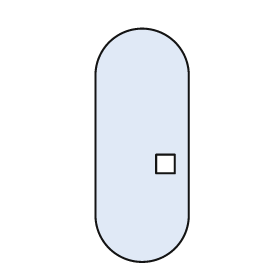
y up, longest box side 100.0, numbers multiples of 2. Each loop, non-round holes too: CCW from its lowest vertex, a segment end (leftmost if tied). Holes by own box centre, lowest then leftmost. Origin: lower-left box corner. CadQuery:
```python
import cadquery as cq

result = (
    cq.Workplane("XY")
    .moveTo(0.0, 20.0)
    .threePointArc((20.0, 0.0), (40.0, 20.0))
    .lineTo(40.0, 80.0)
    .threePointArc((20.0, 100.0), (0.0, 80.0))
    .close()
    .moveTo(26.0, 38.0)
    .lineTo(34.0, 38.0)
    .lineTo(34.0, 46.0)
    .lineTo(26.0, 46.0)
    .close()
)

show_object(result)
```